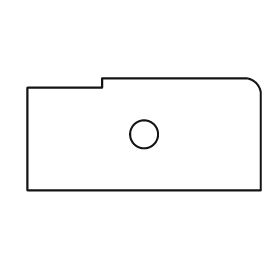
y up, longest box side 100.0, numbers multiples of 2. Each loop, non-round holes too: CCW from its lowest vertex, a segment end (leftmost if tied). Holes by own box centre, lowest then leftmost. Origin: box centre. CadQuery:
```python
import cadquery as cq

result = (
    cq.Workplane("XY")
    .moveTo(-50.0, -24.0)
    .lineTo(50.0, -24.0)
    .lineTo(50.0, 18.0)
    .threePointArc((48.0, 22.0), (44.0, 24.0))
    .lineTo(-18.0, 24.0)
    .lineTo(-18.0, 20.0)
    .lineTo(-50.0, 20.0)
    .close()
    .moveTo(0.0, 0.0)
    .circle(6.0)
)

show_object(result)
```